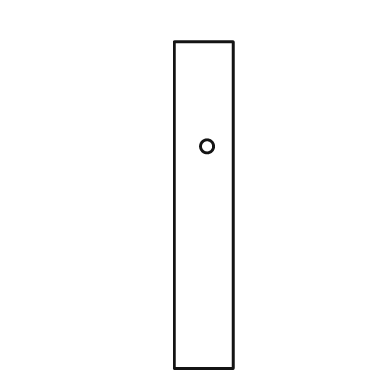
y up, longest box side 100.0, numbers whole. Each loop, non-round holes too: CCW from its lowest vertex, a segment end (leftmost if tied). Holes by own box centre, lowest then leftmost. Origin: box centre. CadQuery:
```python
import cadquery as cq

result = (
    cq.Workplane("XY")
    .moveTo(-9.0, -50.0)
    .lineTo(9.0, -50.0)
    .lineTo(9.0, 50.0)
    .lineTo(-9.0, 50.0)
    .close()
    .moveTo(1.0, 18.0)
    .circle(2.0)
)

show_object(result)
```